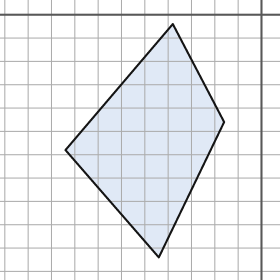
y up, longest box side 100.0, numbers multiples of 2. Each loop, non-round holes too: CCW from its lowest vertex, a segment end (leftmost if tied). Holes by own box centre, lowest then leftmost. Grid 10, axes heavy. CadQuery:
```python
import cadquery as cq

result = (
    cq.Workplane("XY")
    .moveTo(-44.0, -104.0)
    .lineTo(-16.0, -46.0)
    .lineTo(-38.0, -4.0)
    .lineTo(-84.0, -58.0)
    .close()
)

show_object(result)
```